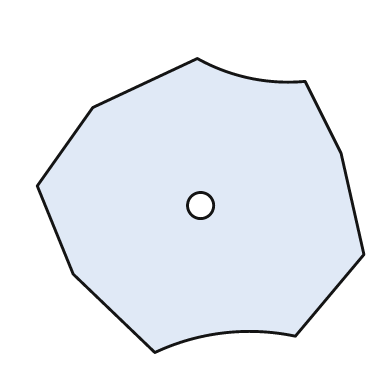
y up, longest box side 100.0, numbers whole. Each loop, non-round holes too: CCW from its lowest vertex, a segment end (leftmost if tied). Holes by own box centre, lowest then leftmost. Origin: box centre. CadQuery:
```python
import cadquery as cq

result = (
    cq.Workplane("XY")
    .moveTo(-14.0, -45.0)
    .threePointArc((7.0, -39.0), (29.0, -40.0))
    .lineTo(50.0, -15.0)
    .lineTo(43.0, 16.0)
    .lineTo(32.0, 38.0)
    .threePointArc((15.0, 39.0), (-1.0, 45.0))
    .lineTo(-33.0, 30.0)
    .lineTo(-50.0, 6.0)
    .lineTo(-39.0, -21.0)
    .close()
    .moveTo(0.0, 0.0)
    .circle(4.0)
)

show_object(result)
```